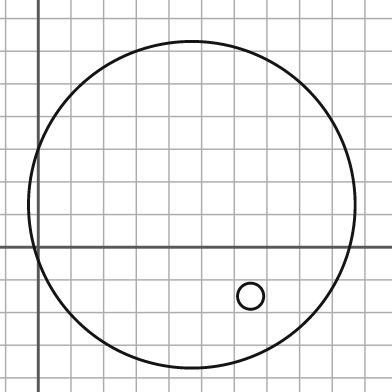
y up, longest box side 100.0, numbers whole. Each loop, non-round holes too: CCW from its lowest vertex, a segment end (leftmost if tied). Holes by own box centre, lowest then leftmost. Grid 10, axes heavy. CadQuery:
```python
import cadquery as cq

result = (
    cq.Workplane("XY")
    .moveTo(47.0, 13.0)
    .circle(50.0)
    .moveTo(65.0, -15.0)
    .circle(4.0)
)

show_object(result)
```